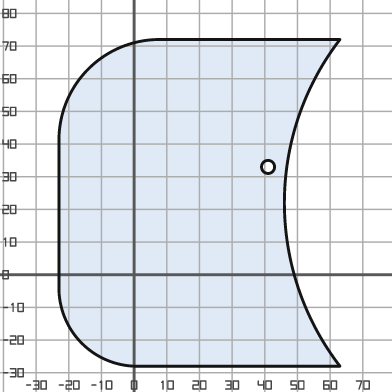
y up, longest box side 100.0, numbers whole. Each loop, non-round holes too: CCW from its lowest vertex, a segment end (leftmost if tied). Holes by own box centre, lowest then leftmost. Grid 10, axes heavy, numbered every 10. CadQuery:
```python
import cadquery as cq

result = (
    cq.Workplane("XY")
    .moveTo(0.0, -28.0)
    .lineTo(63.0, -28.0)
    .threePointArc((46.0, 22.0), (63.0, 72.0))
    .lineTo(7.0, 72.0)
    .threePointArc((-14.0, 63.0), (-23.0, 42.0))
    .lineTo(-23.0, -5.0)
    .threePointArc((-16.0, -21.0), (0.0, -28.0))
    .close()
    .moveTo(41.0, 33.0)
    .circle(2.0)
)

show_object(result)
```